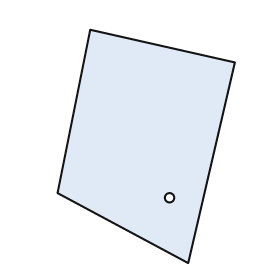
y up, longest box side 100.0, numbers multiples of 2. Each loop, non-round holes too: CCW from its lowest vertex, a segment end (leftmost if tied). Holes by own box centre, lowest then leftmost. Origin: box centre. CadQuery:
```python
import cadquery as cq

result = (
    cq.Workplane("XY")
    .moveTo(18.0, -50.0)
    .lineTo(38.0, 36.0)
    .lineTo(-24.0, 50.0)
    .lineTo(-38.0, -20.0)
    .close()
    .moveTo(10.0, -22.0)
    .circle(2.0)
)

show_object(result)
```